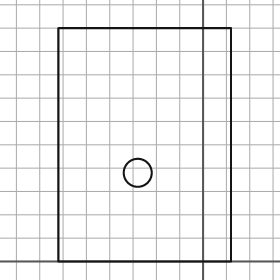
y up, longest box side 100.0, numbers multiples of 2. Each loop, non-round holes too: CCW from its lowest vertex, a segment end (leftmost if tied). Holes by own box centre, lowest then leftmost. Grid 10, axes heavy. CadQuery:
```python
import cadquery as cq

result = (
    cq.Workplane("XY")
    .moveTo(-62.0, 0.0)
    .lineTo(12.0, 0.0)
    .lineTo(12.0, 100.0)
    .lineTo(-62.0, 100.0)
    .close()
    .moveTo(-28.0, 38.0)
    .circle(6.0)
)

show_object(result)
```